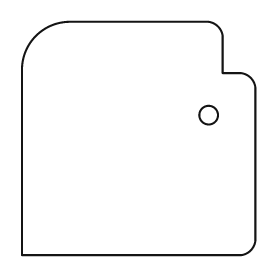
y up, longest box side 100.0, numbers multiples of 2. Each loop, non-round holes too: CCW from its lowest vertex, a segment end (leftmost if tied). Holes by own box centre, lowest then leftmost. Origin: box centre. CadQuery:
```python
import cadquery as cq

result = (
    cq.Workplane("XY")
    .moveTo(-50.0, -50.0)
    .lineTo(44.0, -50.0)
    .threePointArc((48.0, -48.0), (50.0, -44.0))
    .lineTo(50.0, 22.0)
    .threePointArc((48.0, 26.0), (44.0, 28.0))
    .lineTo(36.0, 28.0)
    .lineTo(36.0, 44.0)
    .threePointArc((34.0, 48.0), (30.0, 50.0))
    .lineTo(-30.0, 50.0)
    .threePointArc((-44.0, 44.0), (-50.0, 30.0))
    .close()
    .moveTo(30.0, 10.0)
    .circle(4.0)
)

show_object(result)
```